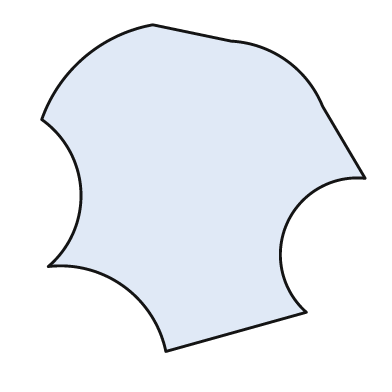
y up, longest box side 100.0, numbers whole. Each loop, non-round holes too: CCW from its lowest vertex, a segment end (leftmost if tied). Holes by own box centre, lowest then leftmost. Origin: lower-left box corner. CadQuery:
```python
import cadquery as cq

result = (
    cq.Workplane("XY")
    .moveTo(38.0, 0.0)
    .lineTo(81.0, 12.0)
    .threePointArc((75.0, 39.0), (99.0, 53.0))
    .lineTo(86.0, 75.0)
    .threePointArc((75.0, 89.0), (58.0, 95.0))
    .lineTo(34.0, 100.0)
    .threePointArc((13.0, 90.0), (0.0, 71.0))
    .threePointArc((12.0, 49.0), (2.0, 26.0))
    .threePointArc((25.0, 20.0), (38.0, 0.0))
    .close()
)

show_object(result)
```